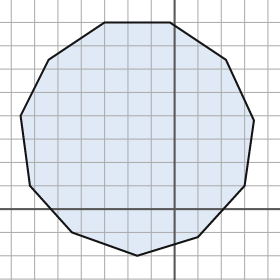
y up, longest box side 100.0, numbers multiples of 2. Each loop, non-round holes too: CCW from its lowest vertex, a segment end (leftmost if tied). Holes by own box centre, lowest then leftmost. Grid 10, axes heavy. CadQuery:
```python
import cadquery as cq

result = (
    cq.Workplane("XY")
    .moveTo(-16.0, -20.0)
    .lineTo(10.0, -12.0)
    .lineTo(30.0, 10.0)
    .lineTo(34.0, 38.0)
    .lineTo(22.0, 64.0)
    .lineTo(-2.0, 80.0)
    .lineTo(-30.0, 80.0)
    .lineTo(-54.0, 64.0)
    .lineTo(-66.0, 40.0)
    .lineTo(-62.0, 10.0)
    .lineTo(-44.0, -10.0)
    .close()
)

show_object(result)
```